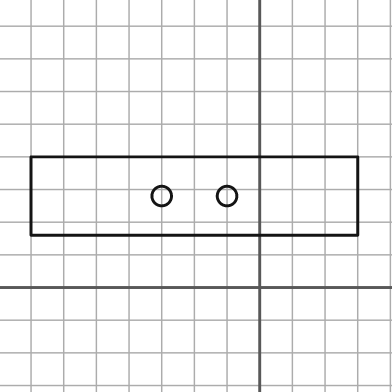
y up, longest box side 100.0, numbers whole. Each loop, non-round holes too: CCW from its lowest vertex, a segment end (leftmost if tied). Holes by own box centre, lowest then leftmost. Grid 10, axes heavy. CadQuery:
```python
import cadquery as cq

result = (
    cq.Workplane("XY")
    .moveTo(-70.0, 16.0)
    .lineTo(30.0, 16.0)
    .lineTo(30.0, 40.0)
    .lineTo(-70.0, 40.0)
    .close()
    .moveTo(-30.0, 28.0)
    .circle(3.0)
    .moveTo(-10.0, 28.0)
    .circle(3.0)
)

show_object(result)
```